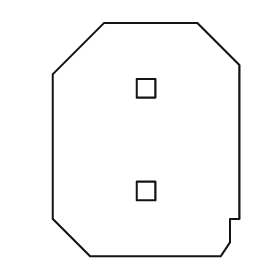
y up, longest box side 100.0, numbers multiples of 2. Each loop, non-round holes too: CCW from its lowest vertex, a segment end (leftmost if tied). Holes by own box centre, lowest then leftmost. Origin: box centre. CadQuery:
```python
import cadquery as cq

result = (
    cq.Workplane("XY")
    .moveTo(-24.0, -50.0)
    .lineTo(32.0, -50.0)
    .lineTo(36.0, -44.0)
    .lineTo(36.0, -34.0)
    .lineTo(40.0, -34.0)
    .lineTo(40.0, 32.0)
    .lineTo(22.0, 50.0)
    .lineTo(-18.0, 50.0)
    .lineTo(-40.0, 28.0)
    .lineTo(-40.0, -34.0)
    .close()
    .moveTo(-4.0, -26.0)
    .lineTo(4.0, -26.0)
    .lineTo(4.0, -18.0)
    .lineTo(-4.0, -18.0)
    .close()
    .moveTo(-4.0, 18.0)
    .lineTo(4.0, 18.0)
    .lineTo(4.0, 26.0)
    .lineTo(-4.0, 26.0)
    .close()
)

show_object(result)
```